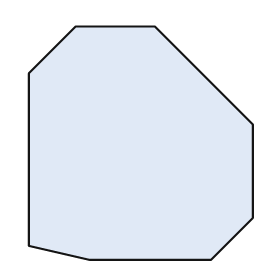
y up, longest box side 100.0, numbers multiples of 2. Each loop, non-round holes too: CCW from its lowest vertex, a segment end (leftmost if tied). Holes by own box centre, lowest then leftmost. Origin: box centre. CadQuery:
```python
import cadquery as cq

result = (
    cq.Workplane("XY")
    .moveTo(-22.0, -50.0)
    .lineTo(30.0, -50.0)
    .lineTo(48.0, -32.0)
    .lineTo(48.0, 8.0)
    .lineTo(6.0, 50.0)
    .lineTo(-28.0, 50.0)
    .lineTo(-48.0, 30.0)
    .lineTo(-48.0, -44.0)
    .close()
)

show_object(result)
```